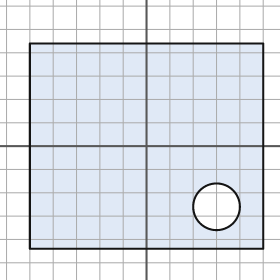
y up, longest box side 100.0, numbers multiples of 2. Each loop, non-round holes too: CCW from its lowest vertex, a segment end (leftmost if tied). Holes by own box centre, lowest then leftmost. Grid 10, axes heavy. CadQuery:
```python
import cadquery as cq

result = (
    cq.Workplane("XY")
    .moveTo(-50.0, -44.0)
    .lineTo(50.0, -44.0)
    .lineTo(50.0, 44.0)
    .lineTo(-50.0, 44.0)
    .close()
    .moveTo(30.0, -26.0)
    .circle(10.0)
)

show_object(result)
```